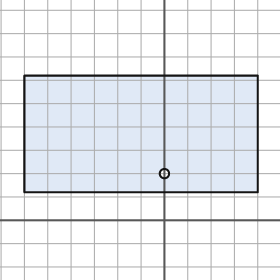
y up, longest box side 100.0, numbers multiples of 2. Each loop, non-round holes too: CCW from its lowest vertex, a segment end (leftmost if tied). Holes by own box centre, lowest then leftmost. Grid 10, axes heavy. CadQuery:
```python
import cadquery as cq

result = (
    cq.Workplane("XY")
    .moveTo(-60.0, 12.0)
    .lineTo(40.0, 12.0)
    .lineTo(40.0, 62.0)
    .lineTo(-60.0, 62.0)
    .close()
    .moveTo(0.0, 20.0)
    .circle(2.0)
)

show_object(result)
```